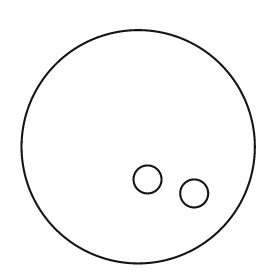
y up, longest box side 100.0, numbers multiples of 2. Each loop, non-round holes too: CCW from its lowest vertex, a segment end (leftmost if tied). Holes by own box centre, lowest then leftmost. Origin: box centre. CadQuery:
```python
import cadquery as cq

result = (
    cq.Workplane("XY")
    .moveTo(0.0, 0.0)
    .circle(50.0)
    .moveTo(24.0, -20.0)
    .circle(6.0)
    .moveTo(4.0, -14.0)
    .circle(6.0)
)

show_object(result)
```